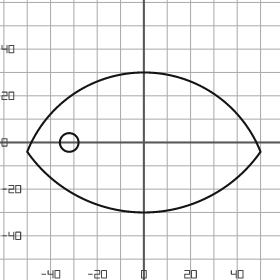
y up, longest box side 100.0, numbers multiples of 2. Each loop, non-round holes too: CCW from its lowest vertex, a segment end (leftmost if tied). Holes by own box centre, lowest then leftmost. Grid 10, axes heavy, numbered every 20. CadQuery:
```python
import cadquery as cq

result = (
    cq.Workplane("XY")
    .moveTo(-50.0, -4.0)
    .threePointArc((0.0, -30.0), (50.0, -4.0))
    .threePointArc((0.0, 30.0), (-50.0, -4.0))
    .close()
    .moveTo(-32.0, 0.0)
    .circle(4.0)
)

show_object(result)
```